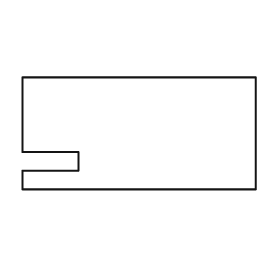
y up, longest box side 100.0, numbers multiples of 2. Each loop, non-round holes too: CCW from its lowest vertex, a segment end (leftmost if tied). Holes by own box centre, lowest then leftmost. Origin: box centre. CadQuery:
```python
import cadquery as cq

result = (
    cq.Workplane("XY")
    .moveTo(-50.0, -24.0)
    .lineTo(50.0, -24.0)
    .lineTo(50.0, 24.0)
    .lineTo(-50.0, 24.0)
    .lineTo(-50.0, -8.0)
    .lineTo(-26.0, -8.0)
    .lineTo(-26.0, -16.0)
    .lineTo(-50.0, -16.0)
    .close()
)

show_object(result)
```